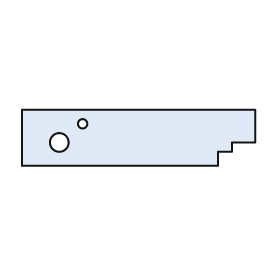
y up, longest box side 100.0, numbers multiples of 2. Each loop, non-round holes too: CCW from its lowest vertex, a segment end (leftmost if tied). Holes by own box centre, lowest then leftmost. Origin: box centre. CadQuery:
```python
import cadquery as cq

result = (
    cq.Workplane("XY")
    .moveTo(-50.0, -12.0)
    .lineTo(34.0, -12.0)
    .lineTo(34.0, -6.0)
    .lineTo(40.0, -6.0)
    .lineTo(40.0, -2.0)
    .lineTo(50.0, -2.0)
    .lineTo(50.0, 12.0)
    .lineTo(-50.0, 12.0)
    .close()
    .moveTo(-34.0, -2.0)
    .circle(4.0)
    .moveTo(-24.0, 6.0)
    .circle(2.0)
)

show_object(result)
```